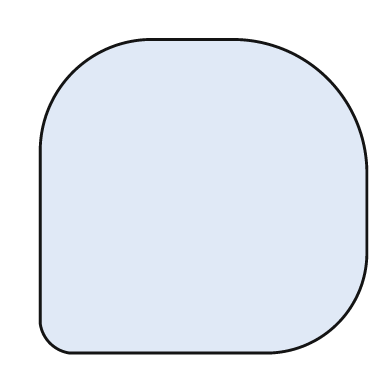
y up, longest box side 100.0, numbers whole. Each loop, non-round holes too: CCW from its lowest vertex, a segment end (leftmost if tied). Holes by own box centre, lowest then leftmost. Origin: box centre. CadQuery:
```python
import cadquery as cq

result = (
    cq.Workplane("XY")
    .moveTo(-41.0, -48.0)
    .lineTo(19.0, -48.0)
    .threePointArc((41.0, -39.0), (50.0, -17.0))
    .lineTo(50.0, 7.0)
    .threePointArc((38.0, 36.0), (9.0, 48.0))
    .lineTo(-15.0, 48.0)
    .threePointArc((-40.0, 38.0), (-50.0, 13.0))
    .lineTo(-50.0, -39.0)
    .threePointArc((-47.0, -45.0), (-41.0, -48.0))
    .close()
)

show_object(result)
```